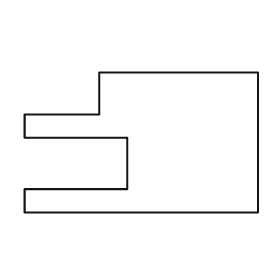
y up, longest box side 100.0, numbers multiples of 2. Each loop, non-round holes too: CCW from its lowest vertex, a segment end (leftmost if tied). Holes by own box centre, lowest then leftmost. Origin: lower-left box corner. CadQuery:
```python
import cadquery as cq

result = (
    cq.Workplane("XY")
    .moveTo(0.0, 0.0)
    .lineTo(100.0, 0.0)
    .lineTo(100.0, 60.0)
    .lineTo(32.0, 60.0)
    .lineTo(32.0, 42.0)
    .lineTo(0.0, 42.0)
    .lineTo(0.0, 32.0)
    .lineTo(44.0, 32.0)
    .lineTo(44.0, 10.0)
    .lineTo(0.0, 10.0)
    .close()
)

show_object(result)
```